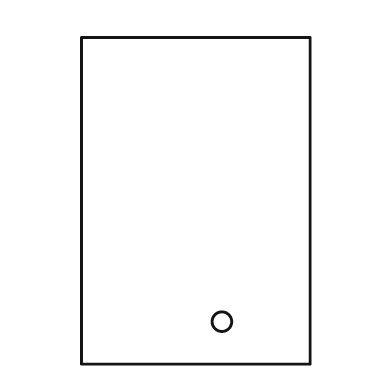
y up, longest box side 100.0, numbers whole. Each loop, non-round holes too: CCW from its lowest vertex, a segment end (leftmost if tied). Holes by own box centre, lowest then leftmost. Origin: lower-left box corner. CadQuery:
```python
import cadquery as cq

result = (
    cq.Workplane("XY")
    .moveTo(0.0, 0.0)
    .lineTo(70.0, 0.0)
    .lineTo(70.0, 100.0)
    .lineTo(0.0, 100.0)
    .close()
    .moveTo(43.0, 13.0)
    .circle(3.0)
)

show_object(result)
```